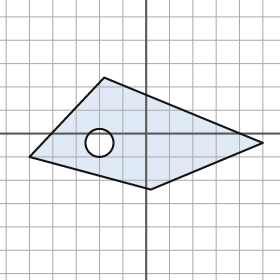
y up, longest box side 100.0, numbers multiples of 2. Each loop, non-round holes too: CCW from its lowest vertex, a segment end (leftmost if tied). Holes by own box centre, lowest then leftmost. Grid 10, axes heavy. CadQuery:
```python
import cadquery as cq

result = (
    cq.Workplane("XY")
    .moveTo(2.0, -24.0)
    .lineTo(50.0, -4.0)
    .lineTo(-18.0, 24.0)
    .lineTo(-50.0, -10.0)
    .close()
    .moveTo(-20.0, -4.0)
    .circle(6.0)
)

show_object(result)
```